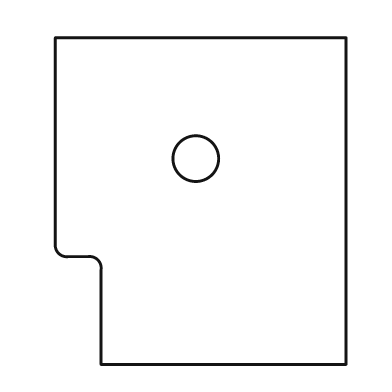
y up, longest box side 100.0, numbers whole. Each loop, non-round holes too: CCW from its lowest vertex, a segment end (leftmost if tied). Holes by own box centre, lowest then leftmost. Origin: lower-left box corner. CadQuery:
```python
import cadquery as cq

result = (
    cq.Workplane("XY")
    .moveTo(14.0, 0.0)
    .lineTo(89.0, 0.0)
    .lineTo(89.0, 100.0)
    .lineTo(0.0, 100.0)
    .lineTo(0.0, 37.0)
    .threePointArc((1.0, 34.0), (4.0, 33.0))
    .lineTo(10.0, 33.0)
    .threePointArc((13.0, 32.0), (14.0, 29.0))
    .close()
    .moveTo(43.0, 63.0)
    .circle(7.0)
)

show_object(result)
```